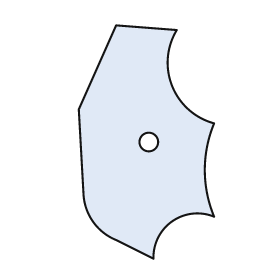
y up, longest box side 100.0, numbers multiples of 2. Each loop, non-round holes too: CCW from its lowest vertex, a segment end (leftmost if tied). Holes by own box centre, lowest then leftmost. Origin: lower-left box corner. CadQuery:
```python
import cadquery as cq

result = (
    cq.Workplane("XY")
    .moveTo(32.0, 0.0)
    .threePointArc((40.0, 16.0), (58.0, 18.0))
    .threePointArc((54.0, 38.0), (58.0, 58.0))
    .threePointArc((40.0, 74.0), (42.0, 98.0))
    .lineTo(16.0, 100.0)
    .lineTo(0.0, 64.0)
    .lineTo(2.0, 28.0)
    .threePointArc((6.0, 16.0), (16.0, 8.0))
    .close()
    .moveTo(30.0, 50.0)
    .circle(4.0)
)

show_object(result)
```